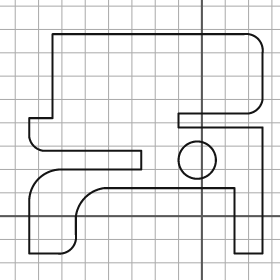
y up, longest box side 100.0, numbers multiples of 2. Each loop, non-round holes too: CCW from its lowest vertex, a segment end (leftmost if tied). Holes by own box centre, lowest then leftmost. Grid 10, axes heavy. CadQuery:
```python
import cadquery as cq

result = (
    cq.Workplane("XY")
    .moveTo(-74.0, -16.0)
    .lineTo(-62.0, -16.0)
    .threePointArc((-56.0, -14.0), (-54.0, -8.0))
    .lineTo(-54.0, 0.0)
    .threePointArc((-50.0, 8.0), (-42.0, 12.0))
    .lineTo(14.0, 12.0)
    .lineTo(14.0, -16.0)
    .lineTo(26.0, -16.0)
    .lineTo(26.0, 38.0)
    .lineTo(-10.0, 38.0)
    .lineTo(-10.0, 44.0)
    .lineTo(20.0, 44.0)
    .threePointArc((24.0, 46.0), (26.0, 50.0))
    .lineTo(26.0, 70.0)
    .threePointArc((24.0, 76.0), (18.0, 78.0))
    .lineTo(-64.0, 78.0)
    .lineTo(-64.0, 42.0)
    .lineTo(-74.0, 42.0)
    .lineTo(-74.0, 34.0)
    .threePointArc((-72.0, 30.0), (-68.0, 28.0))
    .lineTo(-26.0, 28.0)
    .lineTo(-26.0, 20.0)
    .lineTo(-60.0, 20.0)
    .threePointArc((-70.0, 16.0), (-74.0, 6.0))
    .close()
    .moveTo(-2.0, 24.0)
    .circle(8.0)
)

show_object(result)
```